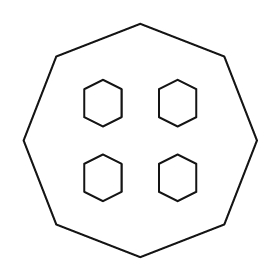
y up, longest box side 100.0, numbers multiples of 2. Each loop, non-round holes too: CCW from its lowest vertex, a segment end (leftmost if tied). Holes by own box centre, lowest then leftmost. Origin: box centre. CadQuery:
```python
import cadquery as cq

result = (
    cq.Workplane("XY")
    .moveTo(0.0, -50.0)
    .lineTo(36.0, -36.0)
    .lineTo(50.0, 0.0)
    .lineTo(36.0, 36.0)
    .lineTo(0.0, 50.0)
    .lineTo(-36.0, 36.0)
    .lineTo(-50.0, 0.0)
    .lineTo(-36.0, -36.0)
    .close()
    .moveTo(-16.0, -26.0)
    .lineTo(-8.0, -22.0)
    .lineTo(-8.0, -10.0)
    .lineTo(-16.0, -6.0)
    .lineTo(-24.0, -10.0)
    .lineTo(-24.0, -22.0)
    .close()
    .moveTo(16.0, -26.0)
    .lineTo(24.0, -22.0)
    .lineTo(24.0, -10.0)
    .lineTo(16.0, -6.0)
    .lineTo(8.0, -10.0)
    .lineTo(8.0, -22.0)
    .close()
    .moveTo(-16.0, 6.0)
    .lineTo(-8.0, 10.0)
    .lineTo(-8.0, 22.0)
    .lineTo(-16.0, 26.0)
    .lineTo(-24.0, 22.0)
    .lineTo(-24.0, 10.0)
    .close()
    .moveTo(16.0, 6.0)
    .lineTo(24.0, 10.0)
    .lineTo(24.0, 22.0)
    .lineTo(16.0, 26.0)
    .lineTo(8.0, 22.0)
    .lineTo(8.0, 10.0)
    .close()
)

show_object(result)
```